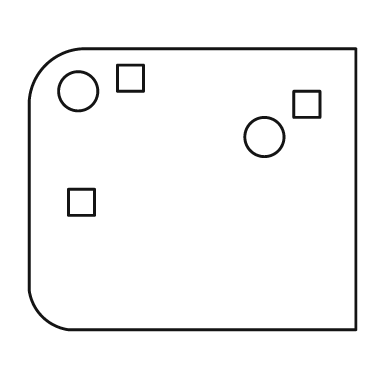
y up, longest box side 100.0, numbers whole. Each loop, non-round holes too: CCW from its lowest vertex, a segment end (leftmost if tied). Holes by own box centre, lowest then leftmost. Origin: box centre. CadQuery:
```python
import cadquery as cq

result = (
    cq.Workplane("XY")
    .moveTo(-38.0, -43.0)
    .lineTo(50.0, -43.0)
    .lineTo(50.0, 43.0)
    .lineTo(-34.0, 43.0)
    .threePointArc((-45.0, 38.0), (-50.0, 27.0))
    .lineTo(-50.0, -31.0)
    .threePointArc((-46.0, -39.0), (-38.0, -43.0))
    .close()
    .moveTo(-38.0, -8.0)
    .lineTo(-30.0, -8.0)
    .lineTo(-30.0, 0.0)
    .lineTo(-38.0, 0.0)
    .close()
    .moveTo(22.0, 16.0)
    .circle(6.0)
    .moveTo(31.0, 22.0)
    .lineTo(39.0, 22.0)
    .lineTo(39.0, 30.0)
    .lineTo(31.0, 30.0)
    .close()
    .moveTo(-35.0, 30.0)
    .circle(6.0)
    .moveTo(-23.0, 30.0)
    .lineTo(-15.0, 30.0)
    .lineTo(-15.0, 38.0)
    .lineTo(-23.0, 38.0)
    .close()
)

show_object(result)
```